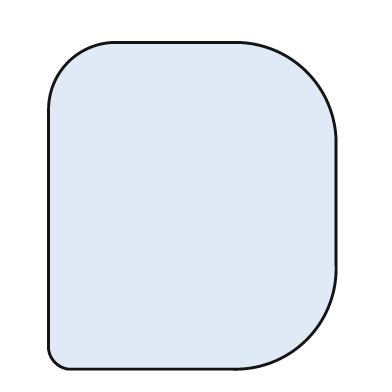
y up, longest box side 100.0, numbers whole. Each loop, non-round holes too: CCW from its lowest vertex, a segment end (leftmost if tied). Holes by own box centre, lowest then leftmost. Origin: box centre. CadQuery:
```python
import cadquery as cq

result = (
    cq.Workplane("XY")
    .moveTo(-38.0, -50.0)
    .lineTo(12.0, -50.0)
    .threePointArc((35.0, -41.0), (44.0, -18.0))
    .lineTo(44.0, 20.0)
    .threePointArc((35.0, 41.0), (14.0, 50.0))
    .lineTo(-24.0, 50.0)
    .threePointArc((-38.0, 44.0), (-44.0, 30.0))
    .lineTo(-44.0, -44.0)
    .threePointArc((-42.0, -48.0), (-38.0, -50.0))
    .close()
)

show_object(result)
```